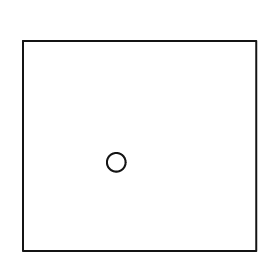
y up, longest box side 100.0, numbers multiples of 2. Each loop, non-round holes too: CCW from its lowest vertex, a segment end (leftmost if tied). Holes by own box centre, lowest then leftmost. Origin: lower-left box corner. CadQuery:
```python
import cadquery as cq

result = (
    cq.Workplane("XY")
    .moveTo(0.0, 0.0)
    .lineTo(100.0, 0.0)
    .lineTo(100.0, 90.0)
    .lineTo(0.0, 90.0)
    .close()
    .moveTo(40.0, 38.0)
    .circle(4.0)
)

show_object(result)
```